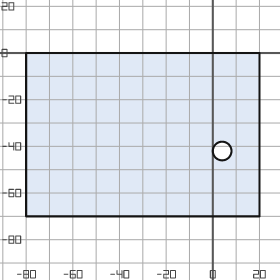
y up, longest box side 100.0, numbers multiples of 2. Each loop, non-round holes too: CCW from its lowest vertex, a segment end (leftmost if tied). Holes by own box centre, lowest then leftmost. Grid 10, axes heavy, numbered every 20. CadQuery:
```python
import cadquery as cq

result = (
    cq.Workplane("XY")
    .moveTo(-80.0, -70.0)
    .lineTo(20.0, -70.0)
    .lineTo(20.0, 0.0)
    .lineTo(-80.0, 0.0)
    .close()
    .moveTo(4.0, -42.0)
    .circle(4.0)
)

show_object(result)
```